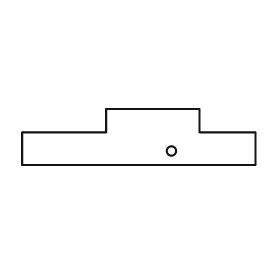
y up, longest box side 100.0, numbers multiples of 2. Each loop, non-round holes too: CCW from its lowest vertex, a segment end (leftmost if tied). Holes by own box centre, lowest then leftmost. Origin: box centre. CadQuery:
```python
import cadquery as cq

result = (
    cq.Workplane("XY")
    .moveTo(-50.0, -12.0)
    .lineTo(50.0, -12.0)
    .lineTo(50.0, 2.0)
    .lineTo(26.0, 2.0)
    .lineTo(26.0, 12.0)
    .lineTo(-14.0, 12.0)
    .lineTo(-14.0, 2.0)
    .lineTo(-50.0, 2.0)
    .close()
    .moveTo(14.0, -6.0)
    .circle(2.0)
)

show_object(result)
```